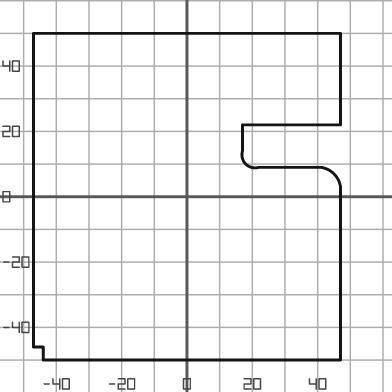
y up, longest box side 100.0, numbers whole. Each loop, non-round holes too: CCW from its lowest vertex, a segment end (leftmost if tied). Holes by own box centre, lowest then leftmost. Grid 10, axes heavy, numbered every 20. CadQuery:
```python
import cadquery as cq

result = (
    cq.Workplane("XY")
    .moveTo(-44.0, -50.0)
    .lineTo(47.0, -50.0)
    .lineTo(47.0, 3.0)
    .threePointArc((45.0, 7.0), (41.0, 9.0))
    .lineTo(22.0, 9.0)
    .threePointArc((18.0, 10.0), (17.0, 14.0))
    .lineTo(17.0, 22.0)
    .lineTo(47.0, 22.0)
    .lineTo(47.0, 50.0)
    .lineTo(-47.0, 50.0)
    .lineTo(-47.0, -46.0)
    .lineTo(-44.0, -46.0)
    .close()
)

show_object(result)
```